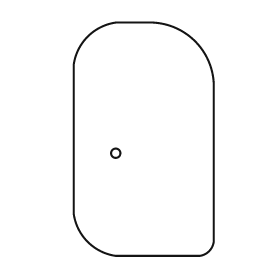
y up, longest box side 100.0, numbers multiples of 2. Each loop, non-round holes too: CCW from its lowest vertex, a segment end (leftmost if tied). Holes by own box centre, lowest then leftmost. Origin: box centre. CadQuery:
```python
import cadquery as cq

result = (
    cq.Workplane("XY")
    .moveTo(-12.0, -50.0)
    .lineTo(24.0, -50.0)
    .threePointArc((28.0, -48.0), (30.0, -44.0))
    .lineTo(30.0, 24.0)
    .threePointArc((22.0, 42.0), (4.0, 50.0))
    .lineTo(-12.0, 50.0)
    .threePointArc((-24.0, 44.0), (-30.0, 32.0))
    .lineTo(-30.0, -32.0)
    .threePointArc((-24.0, -44.0), (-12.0, -50.0))
    .close()
    .moveTo(-12.0, -6.0)
    .circle(2.0)
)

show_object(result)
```